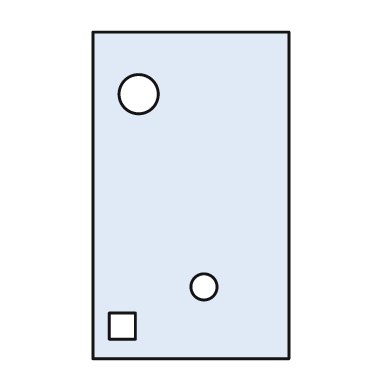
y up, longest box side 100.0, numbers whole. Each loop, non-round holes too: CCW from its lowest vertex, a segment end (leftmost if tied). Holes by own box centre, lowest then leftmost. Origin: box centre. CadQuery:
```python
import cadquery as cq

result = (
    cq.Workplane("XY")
    .moveTo(-30.0, -50.0)
    .lineTo(30.0, -50.0)
    .lineTo(30.0, 50.0)
    .lineTo(-30.0, 50.0)
    .close()
    .moveTo(-25.0, -44.0)
    .lineTo(-17.0, -44.0)
    .lineTo(-17.0, -36.0)
    .lineTo(-25.0, -36.0)
    .close()
    .moveTo(4.0, -28.0)
    .circle(4.0)
    .moveTo(-16.0, 31.0)
    .circle(6.0)
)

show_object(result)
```